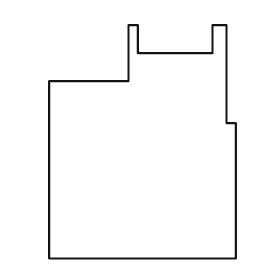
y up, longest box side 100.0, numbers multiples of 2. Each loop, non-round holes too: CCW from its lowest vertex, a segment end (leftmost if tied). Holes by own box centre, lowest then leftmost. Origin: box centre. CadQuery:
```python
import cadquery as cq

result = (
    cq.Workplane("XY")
    .moveTo(-40.0, -50.0)
    .lineTo(40.0, -50.0)
    .lineTo(40.0, 8.0)
    .lineTo(36.0, 8.0)
    .lineTo(36.0, 50.0)
    .lineTo(30.0, 50.0)
    .lineTo(30.0, 38.0)
    .lineTo(-2.0, 38.0)
    .lineTo(-2.0, 50.0)
    .lineTo(-6.0, 50.0)
    .lineTo(-6.0, 26.0)
    .lineTo(-40.0, 26.0)
    .close()
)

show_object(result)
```